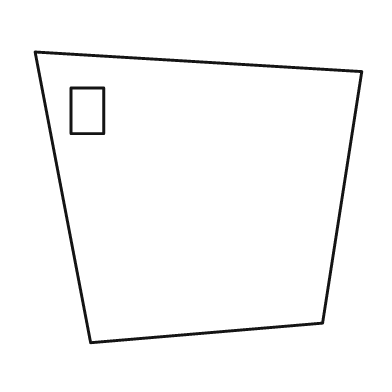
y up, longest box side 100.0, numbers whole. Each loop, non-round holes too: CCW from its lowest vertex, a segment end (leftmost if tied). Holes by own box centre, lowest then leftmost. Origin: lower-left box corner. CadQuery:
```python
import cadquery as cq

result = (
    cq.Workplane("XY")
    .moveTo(17.0, 0.0)
    .lineTo(88.0, 6.0)
    .lineTo(100.0, 83.0)
    .lineTo(0.0, 89.0)
    .close()
    .moveTo(11.0, 64.0)
    .lineTo(21.0, 64.0)
    .lineTo(21.0, 78.0)
    .lineTo(11.0, 78.0)
    .close()
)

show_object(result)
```